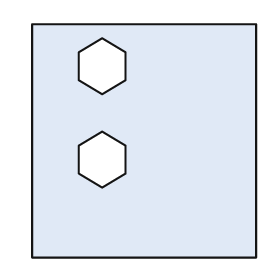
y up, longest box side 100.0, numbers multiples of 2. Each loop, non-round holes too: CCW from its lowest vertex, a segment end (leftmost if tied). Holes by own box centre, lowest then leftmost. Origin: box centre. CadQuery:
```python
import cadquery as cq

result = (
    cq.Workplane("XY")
    .moveTo(-48.0, -50.0)
    .lineTo(48.0, -50.0)
    .lineTo(48.0, 50.0)
    .lineTo(-48.0, 50.0)
    .close()
    .moveTo(-18.0, -20.0)
    .lineTo(-8.0, -14.0)
    .lineTo(-8.0, -2.0)
    .lineTo(-18.0, 4.0)
    .lineTo(-28.0, -2.0)
    .lineTo(-28.0, -14.0)
    .close()
    .moveTo(-18.0, 20.0)
    .lineTo(-8.0, 26.0)
    .lineTo(-8.0, 38.0)
    .lineTo(-18.0, 44.0)
    .lineTo(-28.0, 38.0)
    .lineTo(-28.0, 26.0)
    .close()
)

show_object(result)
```